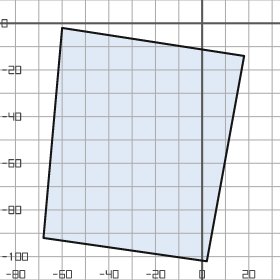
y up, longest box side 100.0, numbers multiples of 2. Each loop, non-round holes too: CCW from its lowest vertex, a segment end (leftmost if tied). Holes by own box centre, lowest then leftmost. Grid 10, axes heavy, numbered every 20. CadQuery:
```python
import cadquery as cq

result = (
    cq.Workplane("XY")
    .moveTo(2.0, -102.0)
    .lineTo(18.0, -14.0)
    .lineTo(-60.0, -2.0)
    .lineTo(-68.0, -92.0)
    .close()
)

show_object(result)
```